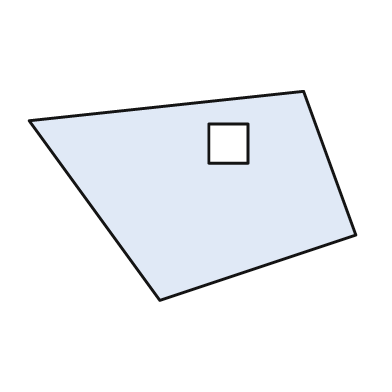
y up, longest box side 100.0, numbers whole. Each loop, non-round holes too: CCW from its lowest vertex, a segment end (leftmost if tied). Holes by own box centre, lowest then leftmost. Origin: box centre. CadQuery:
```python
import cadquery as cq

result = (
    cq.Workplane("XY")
    .moveTo(-10.0, -32.0)
    .lineTo(50.0, -12.0)
    .lineTo(34.0, 32.0)
    .lineTo(-50.0, 23.0)
    .close()
    .moveTo(5.0, 10.0)
    .lineTo(17.0, 10.0)
    .lineTo(17.0, 22.0)
    .lineTo(5.0, 22.0)
    .close()
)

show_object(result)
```